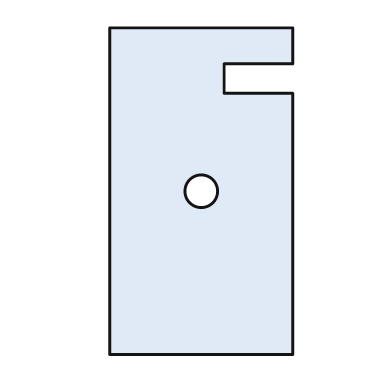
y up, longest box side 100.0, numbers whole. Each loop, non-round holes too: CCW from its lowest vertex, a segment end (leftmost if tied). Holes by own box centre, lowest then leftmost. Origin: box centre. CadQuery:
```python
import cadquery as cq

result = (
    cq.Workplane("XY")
    .moveTo(-28.0, -50.0)
    .lineTo(28.0, -50.0)
    .lineTo(28.0, 30.0)
    .lineTo(7.0, 30.0)
    .lineTo(7.0, 39.0)
    .lineTo(28.0, 39.0)
    .lineTo(28.0, 50.0)
    .lineTo(-28.0, 50.0)
    .close()
    .moveTo(0.0, 0.0)
    .circle(5.0)
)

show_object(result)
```